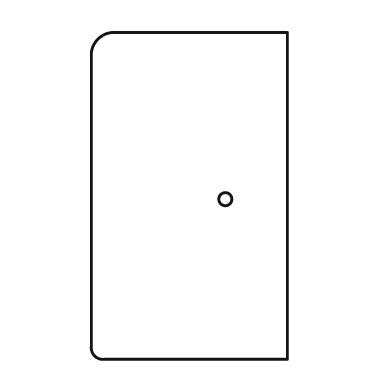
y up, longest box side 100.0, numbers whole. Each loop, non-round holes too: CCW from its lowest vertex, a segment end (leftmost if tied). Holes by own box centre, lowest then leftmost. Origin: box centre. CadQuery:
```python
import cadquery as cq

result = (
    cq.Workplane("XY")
    .moveTo(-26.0, -50.0)
    .lineTo(30.0, -50.0)
    .lineTo(30.0, 50.0)
    .lineTo(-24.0, 50.0)
    .threePointArc((-28.0, 48.0), (-30.0, 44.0))
    .lineTo(-30.0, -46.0)
    .threePointArc((-29.0, -49.0), (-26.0, -50.0))
    .close()
    .moveTo(11.0, -1.0)
    .circle(2.0)
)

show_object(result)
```